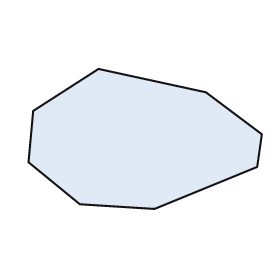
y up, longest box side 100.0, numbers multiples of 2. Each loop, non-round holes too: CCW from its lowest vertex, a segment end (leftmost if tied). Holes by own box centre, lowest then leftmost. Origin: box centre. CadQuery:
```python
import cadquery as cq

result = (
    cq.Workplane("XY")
    .moveTo(4.0, -30.0)
    .lineTo(48.0, -12.0)
    .lineTo(50.0, 2.0)
    .lineTo(26.0, 20.0)
    .lineTo(-20.0, 30.0)
    .lineTo(-48.0, 12.0)
    .lineTo(-50.0, -10.0)
    .lineTo(-28.0, -28.0)
    .close()
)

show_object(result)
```